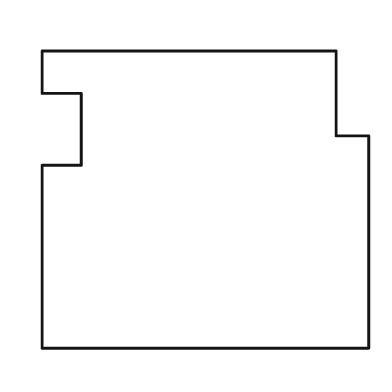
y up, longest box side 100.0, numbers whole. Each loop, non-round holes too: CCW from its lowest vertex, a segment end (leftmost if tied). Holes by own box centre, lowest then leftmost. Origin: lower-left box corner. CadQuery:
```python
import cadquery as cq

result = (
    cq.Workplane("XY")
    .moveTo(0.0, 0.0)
    .lineTo(100.0, 0.0)
    .lineTo(100.0, 65.0)
    .lineTo(90.0, 65.0)
    .lineTo(90.0, 91.0)
    .lineTo(0.0, 91.0)
    .lineTo(0.0, 78.0)
    .lineTo(12.0, 78.0)
    .lineTo(12.0, 56.0)
    .lineTo(0.0, 56.0)
    .close()
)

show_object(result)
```